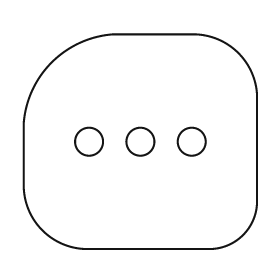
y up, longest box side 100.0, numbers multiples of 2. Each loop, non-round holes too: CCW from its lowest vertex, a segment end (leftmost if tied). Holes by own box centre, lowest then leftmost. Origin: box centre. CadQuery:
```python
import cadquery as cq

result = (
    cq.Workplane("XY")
    .moveTo(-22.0, -46.0)
    .lineTo(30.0, -46.0)
    .threePointArc((44.0, -40.0), (50.0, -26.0))
    .lineTo(50.0, 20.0)
    .threePointArc((42.0, 38.0), (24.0, 46.0))
    .lineTo(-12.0, 46.0)
    .threePointArc((-38.0, 34.0), (-50.0, 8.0))
    .lineTo(-50.0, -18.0)
    .threePointArc((-42.0, -38.0), (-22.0, -46.0))
    .close()
    .moveTo(-22.0, 0.0)
    .circle(6.0)
    .moveTo(0.0, 0.0)
    .circle(6.0)
    .moveTo(22.0, 0.0)
    .circle(6.0)
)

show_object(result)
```